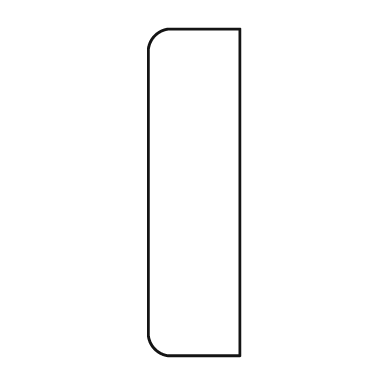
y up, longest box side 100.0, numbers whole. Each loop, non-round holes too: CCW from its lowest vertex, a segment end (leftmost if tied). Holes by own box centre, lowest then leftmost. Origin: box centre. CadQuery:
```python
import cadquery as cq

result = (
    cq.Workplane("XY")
    .moveTo(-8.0, -50.0)
    .lineTo(14.0, -50.0)
    .lineTo(14.0, 50.0)
    .lineTo(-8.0, 50.0)
    .threePointArc((-12.0, 48.0), (-14.0, 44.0))
    .lineTo(-14.0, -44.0)
    .threePointArc((-12.0, -48.0), (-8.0, -50.0))
    .close()
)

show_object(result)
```